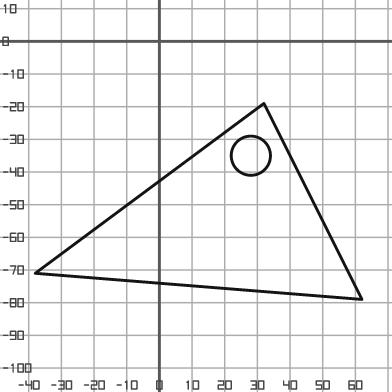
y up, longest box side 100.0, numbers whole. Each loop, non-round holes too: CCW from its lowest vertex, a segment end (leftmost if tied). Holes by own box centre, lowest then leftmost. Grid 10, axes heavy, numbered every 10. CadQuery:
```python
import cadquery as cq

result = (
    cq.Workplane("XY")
    .moveTo(62.0, -79.0)
    .lineTo(32.0, -19.0)
    .lineTo(-38.0, -71.0)
    .close()
    .moveTo(28.0, -35.0)
    .circle(6.0)
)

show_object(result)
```